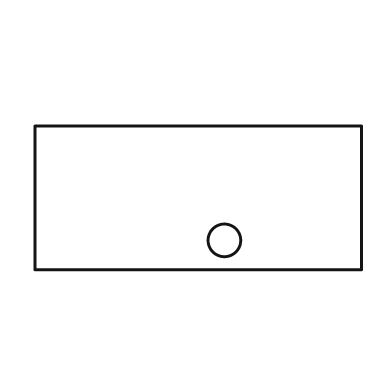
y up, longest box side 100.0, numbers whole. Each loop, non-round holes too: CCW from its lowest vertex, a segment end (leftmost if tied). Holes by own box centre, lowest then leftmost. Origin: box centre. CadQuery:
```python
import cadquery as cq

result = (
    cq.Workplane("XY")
    .moveTo(-50.0, -22.0)
    .lineTo(50.0, -22.0)
    .lineTo(50.0, 22.0)
    .lineTo(-50.0, 22.0)
    .close()
    .moveTo(8.0, -13.0)
    .circle(5.0)
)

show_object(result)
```